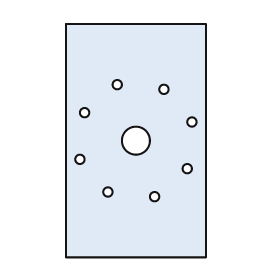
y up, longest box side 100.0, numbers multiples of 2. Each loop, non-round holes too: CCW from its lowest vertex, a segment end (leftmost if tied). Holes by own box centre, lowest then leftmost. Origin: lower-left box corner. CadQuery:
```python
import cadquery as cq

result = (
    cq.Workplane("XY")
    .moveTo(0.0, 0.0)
    .lineTo(60.0, 0.0)
    .lineTo(60.0, 100.0)
    .lineTo(0.0, 100.0)
    .close()
    .moveTo(38.0, 26.0)
    .circle(2.0)
    .moveTo(18.0, 28.0)
    .circle(2.0)
    .moveTo(52.0, 38.0)
    .circle(2.0)
    .moveTo(6.0, 42.0)
    .circle(2.0)
    .moveTo(30.0, 50.0)
    .circle(6.0)
    .moveTo(54.0, 58.0)
    .circle(2.0)
    .moveTo(8.0, 62.0)
    .circle(2.0)
    .moveTo(42.0, 72.0)
    .circle(2.0)
    .moveTo(22.0, 74.0)
    .circle(2.0)
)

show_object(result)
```